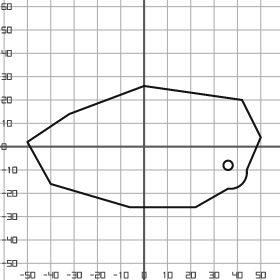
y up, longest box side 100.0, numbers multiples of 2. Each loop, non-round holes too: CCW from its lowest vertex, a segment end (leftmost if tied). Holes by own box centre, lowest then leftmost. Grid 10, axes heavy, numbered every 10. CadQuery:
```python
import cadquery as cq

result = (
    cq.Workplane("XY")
    .moveTo(-6.0, -26.0)
    .lineTo(22.0, -26.0)
    .lineTo(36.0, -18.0)
    .threePointArc((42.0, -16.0), (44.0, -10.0))
    .lineTo(50.0, 4.0)
    .lineTo(42.0, 20.0)
    .lineTo(0.0, 26.0)
    .lineTo(-32.0, 14.0)
    .lineTo(-50.0, 2.0)
    .lineTo(-40.0, -16.0)
    .close()
    .moveTo(36.0, -8.0)
    .circle(2.0)
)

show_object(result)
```